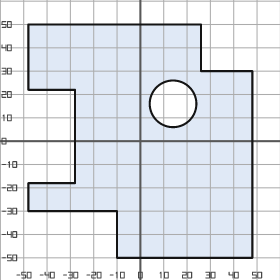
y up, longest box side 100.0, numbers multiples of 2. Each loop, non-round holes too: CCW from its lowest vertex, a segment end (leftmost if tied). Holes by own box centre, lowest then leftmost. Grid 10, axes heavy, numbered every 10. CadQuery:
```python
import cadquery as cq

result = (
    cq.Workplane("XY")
    .moveTo(-10.0, -50.0)
    .lineTo(48.0, -50.0)
    .lineTo(48.0, 30.0)
    .lineTo(26.0, 30.0)
    .lineTo(26.0, 50.0)
    .lineTo(-48.0, 50.0)
    .lineTo(-48.0, 22.0)
    .lineTo(-28.0, 22.0)
    .lineTo(-28.0, -18.0)
    .lineTo(-48.0, -18.0)
    .lineTo(-48.0, -30.0)
    .lineTo(-10.0, -30.0)
    .close()
    .moveTo(14.0, 16.0)
    .circle(10.0)
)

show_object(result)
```